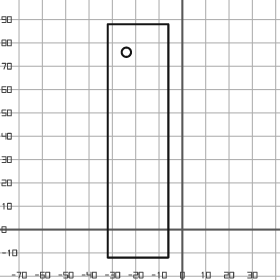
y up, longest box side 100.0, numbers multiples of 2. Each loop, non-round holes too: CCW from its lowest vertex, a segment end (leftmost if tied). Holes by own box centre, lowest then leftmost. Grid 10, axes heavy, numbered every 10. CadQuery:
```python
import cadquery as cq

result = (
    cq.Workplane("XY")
    .moveTo(-32.0, -12.0)
    .lineTo(-6.0, -12.0)
    .lineTo(-6.0, 88.0)
    .lineTo(-32.0, 88.0)
    .close()
    .moveTo(-24.0, 76.0)
    .circle(2.0)
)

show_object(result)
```